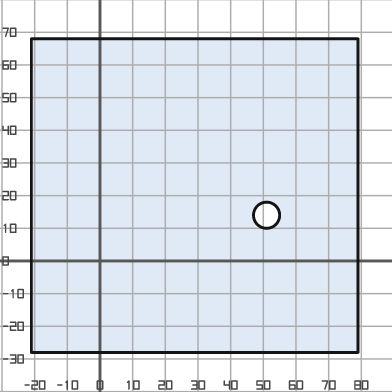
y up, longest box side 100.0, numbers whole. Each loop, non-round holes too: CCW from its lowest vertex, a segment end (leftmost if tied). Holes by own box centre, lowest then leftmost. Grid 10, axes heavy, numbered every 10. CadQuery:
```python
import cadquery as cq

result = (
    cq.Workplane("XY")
    .moveTo(-21.0, -28.0)
    .lineTo(79.0, -28.0)
    .lineTo(79.0, 68.0)
    .lineTo(-21.0, 68.0)
    .close()
    .moveTo(51.0, 14.0)
    .circle(4.0)
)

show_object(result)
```